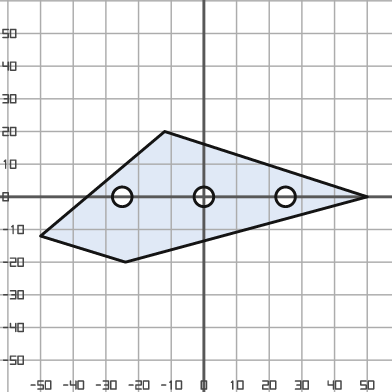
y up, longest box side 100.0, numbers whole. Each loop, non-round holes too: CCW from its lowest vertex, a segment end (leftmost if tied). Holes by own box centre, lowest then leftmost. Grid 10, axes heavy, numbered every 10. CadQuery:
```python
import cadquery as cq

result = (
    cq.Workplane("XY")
    .moveTo(-24.0, -20.0)
    .lineTo(50.0, 0.0)
    .lineTo(-12.0, 20.0)
    .lineTo(-50.0, -12.0)
    .close()
    .moveTo(-25.0, 0.0)
    .circle(3.0)
    .moveTo(0.0, 0.0)
    .circle(3.0)
    .moveTo(25.0, 0.0)
    .circle(3.0)
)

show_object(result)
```